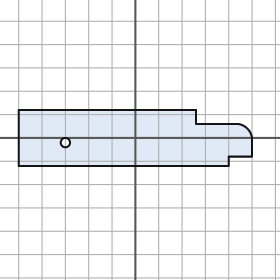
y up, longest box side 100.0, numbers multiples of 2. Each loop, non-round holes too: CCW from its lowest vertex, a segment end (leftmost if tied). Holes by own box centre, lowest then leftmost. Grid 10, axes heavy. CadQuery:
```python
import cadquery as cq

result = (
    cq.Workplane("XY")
    .moveTo(-50.0, -12.0)
    .lineTo(40.0, -12.0)
    .lineTo(40.0, -8.0)
    .lineTo(50.0, -8.0)
    .lineTo(50.0, 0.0)
    .threePointArc((48.0, 4.0), (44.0, 6.0))
    .lineTo(26.0, 6.0)
    .lineTo(26.0, 12.0)
    .lineTo(-50.0, 12.0)
    .close()
    .moveTo(-30.0, -2.0)
    .circle(2.0)
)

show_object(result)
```